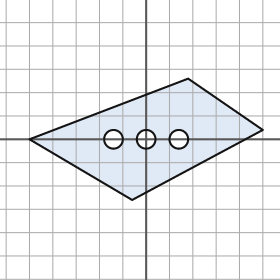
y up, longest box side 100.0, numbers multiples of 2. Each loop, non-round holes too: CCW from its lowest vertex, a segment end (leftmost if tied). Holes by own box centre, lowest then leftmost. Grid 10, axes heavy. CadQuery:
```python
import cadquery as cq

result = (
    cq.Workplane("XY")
    .moveTo(-6.0, -26.0)
    .lineTo(50.0, 4.0)
    .lineTo(18.0, 26.0)
    .lineTo(-50.0, 0.0)
    .close()
    .moveTo(-14.0, 0.0)
    .circle(4.0)
    .moveTo(0.0, 0.0)
    .circle(4.0)
    .moveTo(14.0, 0.0)
    .circle(4.0)
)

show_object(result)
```